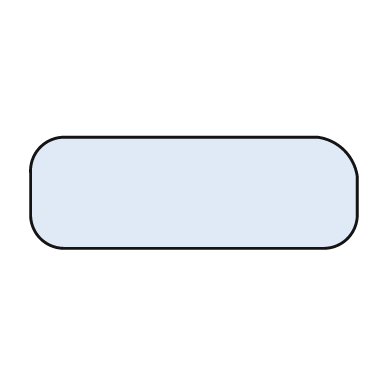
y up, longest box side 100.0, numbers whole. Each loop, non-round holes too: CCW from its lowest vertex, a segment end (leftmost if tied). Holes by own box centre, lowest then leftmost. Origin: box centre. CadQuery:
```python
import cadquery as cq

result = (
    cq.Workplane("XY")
    .moveTo(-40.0, -17.0)
    .lineTo(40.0, -17.0)
    .threePointArc((47.0, -14.0), (50.0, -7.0))
    .lineTo(50.0, 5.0)
    .threePointArc((46.0, 13.0), (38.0, 17.0))
    .lineTo(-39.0, 17.0)
    .threePointArc((-47.0, 14.0), (-50.0, 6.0))
    .lineTo(-50.0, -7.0)
    .threePointArc((-47.0, -14.0), (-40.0, -17.0))
    .close()
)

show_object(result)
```